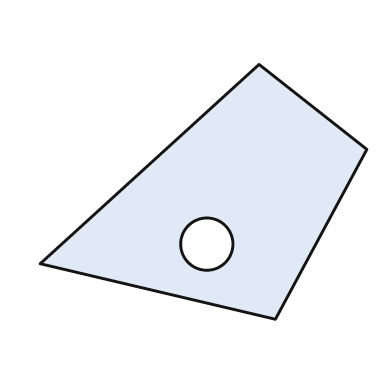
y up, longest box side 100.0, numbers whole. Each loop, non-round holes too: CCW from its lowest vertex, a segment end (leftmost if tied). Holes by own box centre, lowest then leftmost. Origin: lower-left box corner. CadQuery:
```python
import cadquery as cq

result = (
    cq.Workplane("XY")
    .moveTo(72.0, 0.0)
    .lineTo(100.0, 52.0)
    .lineTo(67.0, 78.0)
    .lineTo(0.0, 17.0)
    .close()
    .moveTo(51.0, 23.0)
    .circle(8.0)
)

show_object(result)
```